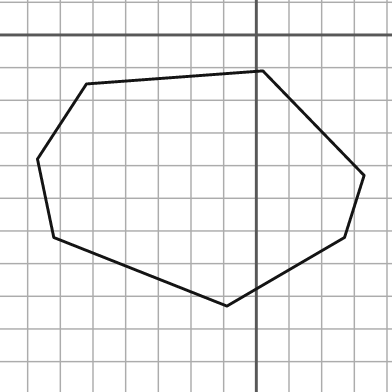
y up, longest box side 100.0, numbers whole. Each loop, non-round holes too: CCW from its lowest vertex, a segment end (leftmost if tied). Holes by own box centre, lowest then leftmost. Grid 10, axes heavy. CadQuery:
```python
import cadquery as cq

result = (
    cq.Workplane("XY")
    .moveTo(-9.0, -83.0)
    .lineTo(27.0, -62.0)
    .lineTo(33.0, -43.0)
    .lineTo(2.0, -11.0)
    .lineTo(-52.0, -15.0)
    .lineTo(-67.0, -38.0)
    .lineTo(-62.0, -62.0)
    .close()
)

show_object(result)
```